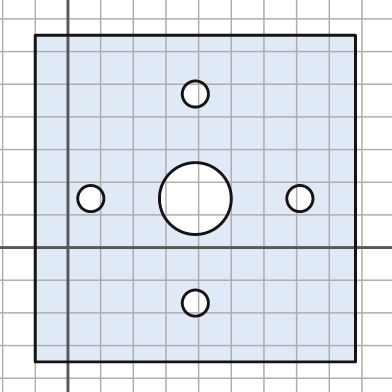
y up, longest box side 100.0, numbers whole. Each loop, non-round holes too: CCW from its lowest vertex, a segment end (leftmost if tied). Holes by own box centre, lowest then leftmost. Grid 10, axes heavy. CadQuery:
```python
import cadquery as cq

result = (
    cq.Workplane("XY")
    .moveTo(-10.0, -35.0)
    .lineTo(88.0, -35.0)
    .lineTo(88.0, 65.0)
    .lineTo(-10.0, 65.0)
    .close()
    .moveTo(39.0, -17.0)
    .circle(4.0)
    .moveTo(7.0, 15.0)
    .circle(4.0)
    .moveTo(39.0, 15.0)
    .circle(11.0)
    .moveTo(71.0, 15.0)
    .circle(4.0)
    .moveTo(39.0, 47.0)
    .circle(4.0)
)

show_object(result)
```